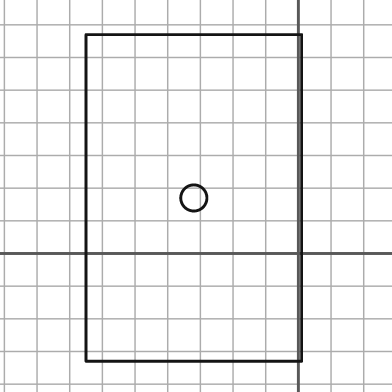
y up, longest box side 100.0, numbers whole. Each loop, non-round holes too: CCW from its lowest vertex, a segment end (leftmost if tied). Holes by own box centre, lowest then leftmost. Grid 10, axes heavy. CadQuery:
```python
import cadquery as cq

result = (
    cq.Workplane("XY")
    .moveTo(-65.0, -33.0)
    .lineTo(1.0, -33.0)
    .lineTo(1.0, 67.0)
    .lineTo(-65.0, 67.0)
    .close()
    .moveTo(-32.0, 17.0)
    .circle(4.0)
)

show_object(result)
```